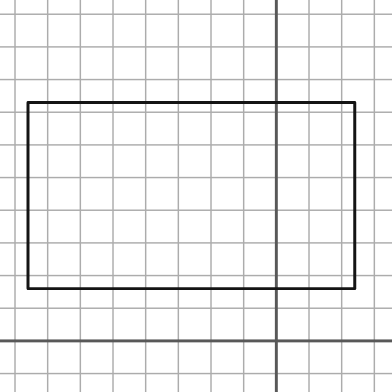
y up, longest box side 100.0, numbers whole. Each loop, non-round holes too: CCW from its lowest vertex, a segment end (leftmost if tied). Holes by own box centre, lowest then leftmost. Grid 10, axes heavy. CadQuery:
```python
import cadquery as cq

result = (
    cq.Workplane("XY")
    .moveTo(-76.0, 16.0)
    .lineTo(24.0, 16.0)
    .lineTo(24.0, 73.0)
    .lineTo(-76.0, 73.0)
    .close()
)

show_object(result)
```